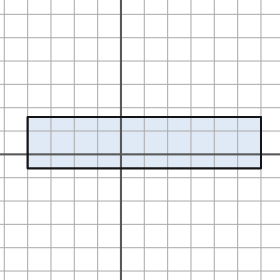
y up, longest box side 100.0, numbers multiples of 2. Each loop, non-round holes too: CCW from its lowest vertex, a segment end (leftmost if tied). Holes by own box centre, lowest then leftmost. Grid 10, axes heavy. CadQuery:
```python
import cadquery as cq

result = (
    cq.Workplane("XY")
    .moveTo(-40.0, -6.0)
    .lineTo(60.0, -6.0)
    .lineTo(60.0, 16.0)
    .lineTo(-40.0, 16.0)
    .close()
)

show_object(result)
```